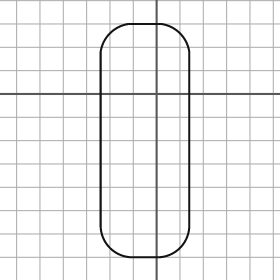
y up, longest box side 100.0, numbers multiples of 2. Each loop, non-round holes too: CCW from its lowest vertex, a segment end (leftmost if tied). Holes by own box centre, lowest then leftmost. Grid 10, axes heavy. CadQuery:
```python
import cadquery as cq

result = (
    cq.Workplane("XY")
    .moveTo(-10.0, -70.0)
    .lineTo(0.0, -70.0)
    .threePointArc((10.0, -66.0), (14.0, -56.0))
    .lineTo(14.0, 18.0)
    .threePointArc((10.0, 26.0), (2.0, 30.0))
    .lineTo(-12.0, 30.0)
    .threePointArc((-20.0, 26.0), (-24.0, 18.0))
    .lineTo(-24.0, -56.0)
    .threePointArc((-20.0, -66.0), (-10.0, -70.0))
    .close()
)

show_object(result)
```